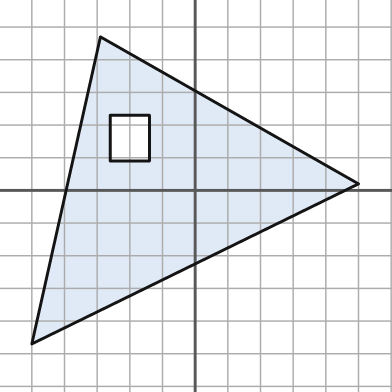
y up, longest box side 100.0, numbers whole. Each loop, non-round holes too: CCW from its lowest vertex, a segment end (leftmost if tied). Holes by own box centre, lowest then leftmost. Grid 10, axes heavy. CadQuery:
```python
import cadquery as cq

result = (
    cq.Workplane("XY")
    .moveTo(-50.0, -47.0)
    .lineTo(50.0, 2.0)
    .lineTo(-29.0, 47.0)
    .close()
    .moveTo(-26.0, 9.0)
    .lineTo(-14.0, 9.0)
    .lineTo(-14.0, 23.0)
    .lineTo(-26.0, 23.0)
    .close()
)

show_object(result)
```